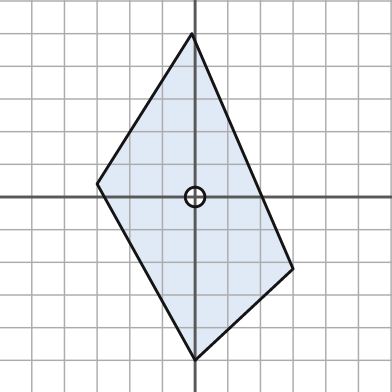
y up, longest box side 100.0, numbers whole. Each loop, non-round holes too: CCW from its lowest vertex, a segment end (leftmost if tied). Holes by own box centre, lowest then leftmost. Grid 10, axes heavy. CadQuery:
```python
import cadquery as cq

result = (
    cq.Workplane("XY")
    .moveTo(0.0, -50.0)
    .lineTo(30.0, -22.0)
    .lineTo(-1.0, 50.0)
    .lineTo(-30.0, 4.0)
    .close()
    .moveTo(0.0, 0.0)
    .circle(3.0)
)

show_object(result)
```